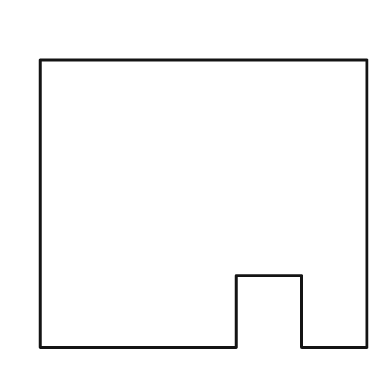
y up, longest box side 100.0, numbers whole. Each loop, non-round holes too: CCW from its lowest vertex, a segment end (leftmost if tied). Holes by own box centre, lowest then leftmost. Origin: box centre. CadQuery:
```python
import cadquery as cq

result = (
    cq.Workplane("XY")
    .moveTo(-50.0, -44.0)
    .lineTo(10.0, -44.0)
    .lineTo(10.0, -22.0)
    .lineTo(30.0, -22.0)
    .lineTo(30.0, -44.0)
    .lineTo(50.0, -44.0)
    .lineTo(50.0, 44.0)
    .lineTo(-50.0, 44.0)
    .close()
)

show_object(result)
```